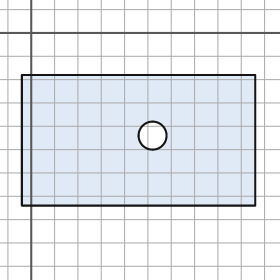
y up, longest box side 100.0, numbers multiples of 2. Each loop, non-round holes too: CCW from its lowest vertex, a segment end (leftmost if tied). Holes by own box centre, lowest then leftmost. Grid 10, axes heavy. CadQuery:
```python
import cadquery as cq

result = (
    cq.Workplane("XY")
    .moveTo(-4.0, -74.0)
    .lineTo(96.0, -74.0)
    .lineTo(96.0, -18.0)
    .lineTo(-4.0, -18.0)
    .close()
    .moveTo(52.0, -44.0)
    .circle(6.0)
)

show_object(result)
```